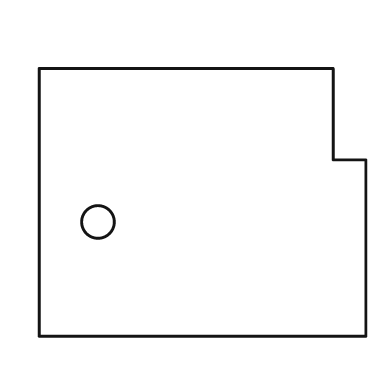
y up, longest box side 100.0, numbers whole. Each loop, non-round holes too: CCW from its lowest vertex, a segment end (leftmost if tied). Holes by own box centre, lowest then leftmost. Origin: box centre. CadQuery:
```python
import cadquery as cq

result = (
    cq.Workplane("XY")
    .moveTo(-50.0, -41.0)
    .lineTo(50.0, -41.0)
    .lineTo(50.0, 13.0)
    .lineTo(40.0, 13.0)
    .lineTo(40.0, 41.0)
    .lineTo(-50.0, 41.0)
    .close()
    .moveTo(-32.0, -6.0)
    .circle(5.0)
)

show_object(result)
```